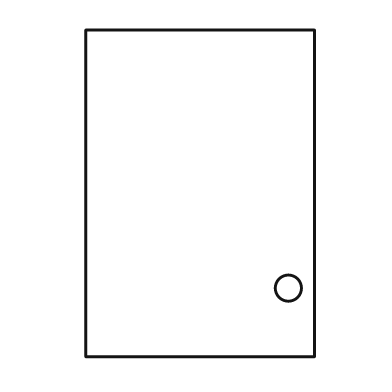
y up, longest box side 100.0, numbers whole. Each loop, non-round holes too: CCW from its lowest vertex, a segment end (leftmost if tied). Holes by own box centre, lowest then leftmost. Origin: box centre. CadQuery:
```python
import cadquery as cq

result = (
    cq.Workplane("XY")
    .moveTo(-35.0, -50.0)
    .lineTo(35.0, -50.0)
    .lineTo(35.0, 50.0)
    .lineTo(-35.0, 50.0)
    .close()
    .moveTo(27.0, -29.0)
    .circle(4.0)
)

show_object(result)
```